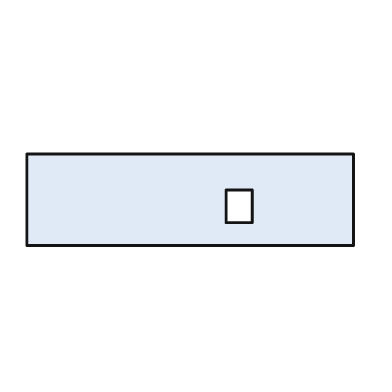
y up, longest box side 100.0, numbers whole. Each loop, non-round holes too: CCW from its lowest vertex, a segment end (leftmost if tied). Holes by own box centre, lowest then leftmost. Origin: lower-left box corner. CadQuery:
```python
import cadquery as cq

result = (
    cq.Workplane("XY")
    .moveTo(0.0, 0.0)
    .lineTo(100.0, 0.0)
    .lineTo(100.0, 28.0)
    .lineTo(0.0, 28.0)
    .close()
    .moveTo(61.0, 7.0)
    .lineTo(69.0, 7.0)
    .lineTo(69.0, 17.0)
    .lineTo(61.0, 17.0)
    .close()
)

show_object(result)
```